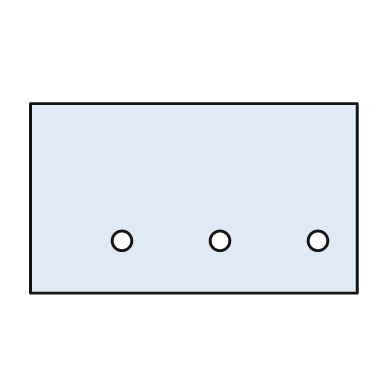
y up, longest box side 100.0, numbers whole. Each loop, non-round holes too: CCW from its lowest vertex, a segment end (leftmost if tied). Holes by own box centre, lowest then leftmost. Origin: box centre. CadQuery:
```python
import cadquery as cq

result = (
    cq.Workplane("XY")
    .moveTo(-50.0, -29.0)
    .lineTo(50.0, -29.0)
    .lineTo(50.0, 29.0)
    .lineTo(-50.0, 29.0)
    .close()
    .moveTo(-22.0, -13.0)
    .circle(3.0)
    .moveTo(8.0, -13.0)
    .circle(3.0)
    .moveTo(38.0, -13.0)
    .circle(3.0)
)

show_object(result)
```